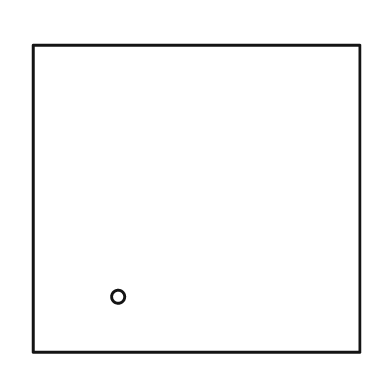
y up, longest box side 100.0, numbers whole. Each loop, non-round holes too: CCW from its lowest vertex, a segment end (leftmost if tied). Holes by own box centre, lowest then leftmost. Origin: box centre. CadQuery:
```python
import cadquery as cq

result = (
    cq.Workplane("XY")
    .moveTo(-50.0, -47.0)
    .lineTo(50.0, -47.0)
    .lineTo(50.0, 47.0)
    .lineTo(-50.0, 47.0)
    .close()
    .moveTo(-24.0, -30.0)
    .circle(2.0)
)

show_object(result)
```